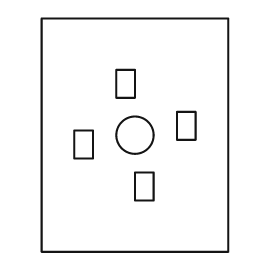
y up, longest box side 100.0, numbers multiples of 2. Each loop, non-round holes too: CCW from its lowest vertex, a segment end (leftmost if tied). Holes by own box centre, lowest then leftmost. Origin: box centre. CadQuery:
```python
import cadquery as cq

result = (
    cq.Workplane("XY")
    .moveTo(-40.0, -50.0)
    .lineTo(40.0, -50.0)
    .lineTo(40.0, 50.0)
    .lineTo(-40.0, 50.0)
    .close()
    .moveTo(0.0, -28.0)
    .lineTo(8.0, -28.0)
    .lineTo(8.0, -16.0)
    .lineTo(0.0, -16.0)
    .close()
    .moveTo(-26.0, -10.0)
    .lineTo(-18.0, -10.0)
    .lineTo(-18.0, 2.0)
    .lineTo(-26.0, 2.0)
    .close()
    .moveTo(0.0, 0.0)
    .circle(8.0)
    .moveTo(18.0, -2.0)
    .lineTo(26.0, -2.0)
    .lineTo(26.0, 10.0)
    .lineTo(18.0, 10.0)
    .close()
    .moveTo(-8.0, 16.0)
    .lineTo(0.0, 16.0)
    .lineTo(0.0, 28.0)
    .lineTo(-8.0, 28.0)
    .close()
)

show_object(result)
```